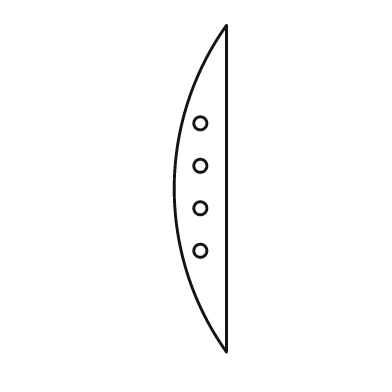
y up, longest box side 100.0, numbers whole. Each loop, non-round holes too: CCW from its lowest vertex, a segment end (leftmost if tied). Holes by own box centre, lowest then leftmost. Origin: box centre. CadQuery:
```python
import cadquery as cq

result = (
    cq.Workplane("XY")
    .moveTo(8.0, -50.0)
    .lineTo(8.0, 50.0)
    .threePointArc((-8.0, 0.0), (8.0, -50.0))
    .close()
    .moveTo(0.0, -19.0)
    .circle(2.0)
    .moveTo(0.0, -6.0)
    .circle(2.0)
    .moveTo(0.0, 7.0)
    .circle(2.0)
    .moveTo(0.0, 20.0)
    .circle(2.0)
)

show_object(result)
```